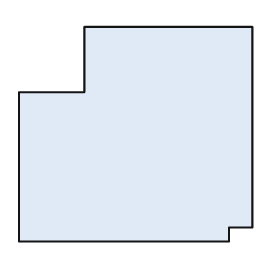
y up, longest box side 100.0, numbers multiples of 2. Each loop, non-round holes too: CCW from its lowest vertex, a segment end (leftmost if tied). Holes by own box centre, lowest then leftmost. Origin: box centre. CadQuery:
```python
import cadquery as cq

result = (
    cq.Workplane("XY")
    .moveTo(-50.0, -46.0)
    .lineTo(40.0, -46.0)
    .lineTo(40.0, -40.0)
    .lineTo(50.0, -40.0)
    .lineTo(50.0, 46.0)
    .lineTo(-22.0, 46.0)
    .lineTo(-22.0, 18.0)
    .lineTo(-50.0, 18.0)
    .close()
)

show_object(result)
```